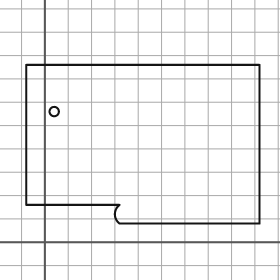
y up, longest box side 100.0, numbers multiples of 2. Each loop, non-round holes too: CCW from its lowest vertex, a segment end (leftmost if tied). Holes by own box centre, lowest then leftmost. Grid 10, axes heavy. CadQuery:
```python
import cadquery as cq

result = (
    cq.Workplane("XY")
    .moveTo(32.0, 8.0)
    .lineTo(92.0, 8.0)
    .lineTo(92.0, 76.0)
    .lineTo(-8.0, 76.0)
    .lineTo(-8.0, 16.0)
    .lineTo(32.0, 16.0)
    .threePointArc((30.0, 12.0), (32.0, 8.0))
    .close()
    .moveTo(4.0, 56.0)
    .circle(2.0)
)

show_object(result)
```